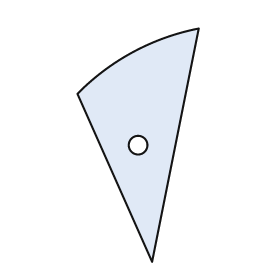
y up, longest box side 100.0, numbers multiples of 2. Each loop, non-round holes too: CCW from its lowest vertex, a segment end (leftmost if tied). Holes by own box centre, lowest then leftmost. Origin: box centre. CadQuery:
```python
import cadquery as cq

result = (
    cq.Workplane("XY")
    .moveTo(6.0, -50.0)
    .lineTo(26.0, 50.0)
    .threePointArc((-2.0, 40.0), (-26.0, 22.0))
    .close()
    .moveTo(0.0, 0.0)
    .circle(4.0)
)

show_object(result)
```